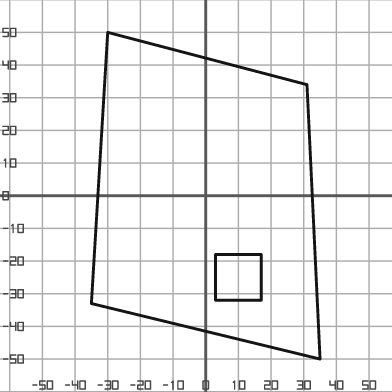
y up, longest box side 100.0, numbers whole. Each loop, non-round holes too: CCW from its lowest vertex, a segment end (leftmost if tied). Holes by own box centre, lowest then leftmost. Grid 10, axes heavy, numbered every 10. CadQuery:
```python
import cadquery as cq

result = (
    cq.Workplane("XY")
    .moveTo(35.0, -50.0)
    .lineTo(31.0, 34.0)
    .lineTo(-30.0, 50.0)
    .lineTo(-35.0, -33.0)
    .close()
    .moveTo(3.0, -32.0)
    .lineTo(17.0, -32.0)
    .lineTo(17.0, -18.0)
    .lineTo(3.0, -18.0)
    .close()
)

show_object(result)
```